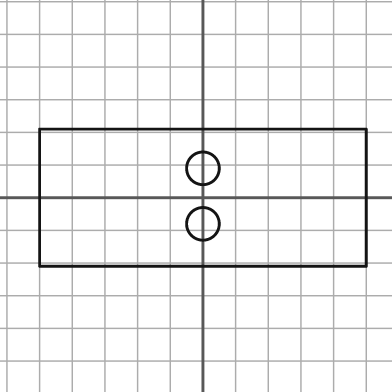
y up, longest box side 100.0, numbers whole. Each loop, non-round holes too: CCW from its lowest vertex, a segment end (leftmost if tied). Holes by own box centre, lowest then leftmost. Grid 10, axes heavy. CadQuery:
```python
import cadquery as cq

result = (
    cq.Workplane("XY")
    .moveTo(-50.0, -21.0)
    .lineTo(50.0, -21.0)
    .lineTo(50.0, 21.0)
    .lineTo(-50.0, 21.0)
    .close()
    .moveTo(0.0, -8.0)
    .circle(5.0)
    .moveTo(0.0, 9.0)
    .circle(5.0)
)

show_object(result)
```